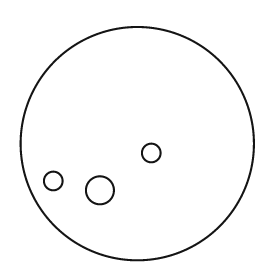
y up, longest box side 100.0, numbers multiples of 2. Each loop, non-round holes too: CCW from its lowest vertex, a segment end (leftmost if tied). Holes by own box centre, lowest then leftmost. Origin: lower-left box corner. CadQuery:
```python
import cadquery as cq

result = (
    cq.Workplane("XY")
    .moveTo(50.0, 50.0)
    .circle(50.0)
    .moveTo(34.0, 30.0)
    .circle(6.0)
    .moveTo(14.0, 34.0)
    .circle(4.0)
    .moveTo(56.0, 46.0)
    .circle(4.0)
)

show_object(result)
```